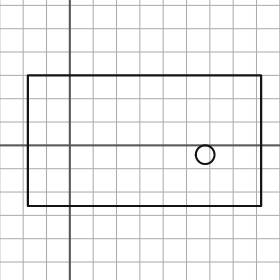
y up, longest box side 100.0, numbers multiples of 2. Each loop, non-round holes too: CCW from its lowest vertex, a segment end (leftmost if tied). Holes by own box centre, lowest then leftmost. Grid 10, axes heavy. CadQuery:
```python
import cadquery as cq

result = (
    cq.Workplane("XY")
    .moveTo(-18.0, -26.0)
    .lineTo(82.0, -26.0)
    .lineTo(82.0, 30.0)
    .lineTo(-18.0, 30.0)
    .close()
    .moveTo(58.0, -4.0)
    .circle(4.0)
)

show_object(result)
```